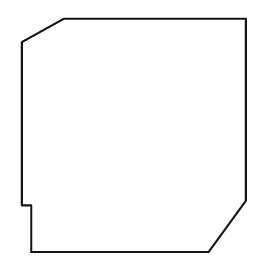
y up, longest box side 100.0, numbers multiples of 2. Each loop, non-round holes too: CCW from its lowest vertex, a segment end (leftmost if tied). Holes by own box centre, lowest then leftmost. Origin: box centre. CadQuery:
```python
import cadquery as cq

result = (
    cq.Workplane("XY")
    .moveTo(-44.0, -50.0)
    .lineTo(32.0, -50.0)
    .lineTo(48.0, -28.0)
    .lineTo(48.0, 50.0)
    .lineTo(-30.0, 50.0)
    .lineTo(-48.0, 40.0)
    .lineTo(-48.0, -30.0)
    .lineTo(-44.0, -30.0)
    .close()
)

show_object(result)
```